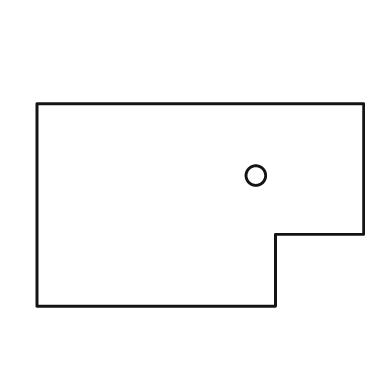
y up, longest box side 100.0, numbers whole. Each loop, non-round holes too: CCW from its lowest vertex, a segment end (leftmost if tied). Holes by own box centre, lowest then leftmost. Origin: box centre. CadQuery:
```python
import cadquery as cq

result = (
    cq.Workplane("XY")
    .moveTo(-50.0, -31.0)
    .lineTo(23.0, -31.0)
    .lineTo(23.0, -9.0)
    .lineTo(50.0, -9.0)
    .lineTo(50.0, 31.0)
    .lineTo(-50.0, 31.0)
    .close()
    .moveTo(17.0, 9.0)
    .circle(3.0)
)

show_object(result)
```